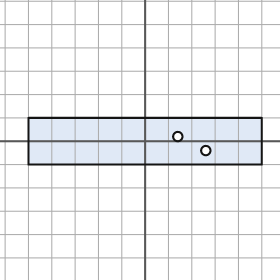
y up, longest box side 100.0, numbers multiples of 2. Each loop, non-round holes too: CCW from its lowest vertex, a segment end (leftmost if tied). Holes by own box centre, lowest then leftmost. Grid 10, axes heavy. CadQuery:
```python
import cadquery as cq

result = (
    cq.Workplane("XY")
    .moveTo(-50.0, -10.0)
    .lineTo(50.0, -10.0)
    .lineTo(50.0, 10.0)
    .lineTo(-50.0, 10.0)
    .close()
    .moveTo(26.0, -4.0)
    .circle(2.0)
    .moveTo(14.0, 2.0)
    .circle(2.0)
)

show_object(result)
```